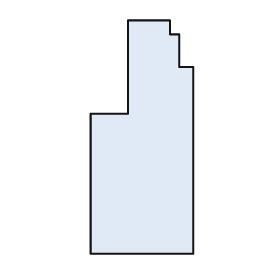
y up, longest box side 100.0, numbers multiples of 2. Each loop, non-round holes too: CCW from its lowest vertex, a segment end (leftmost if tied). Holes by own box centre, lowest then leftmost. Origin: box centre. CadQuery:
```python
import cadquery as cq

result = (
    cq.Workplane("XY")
    .moveTo(-22.0, -50.0)
    .lineTo(22.0, -50.0)
    .lineTo(22.0, 30.0)
    .lineTo(16.0, 30.0)
    .lineTo(16.0, 44.0)
    .lineTo(12.0, 44.0)
    .lineTo(12.0, 50.0)
    .lineTo(-6.0, 50.0)
    .lineTo(-6.0, 10.0)
    .lineTo(-22.0, 10.0)
    .close()
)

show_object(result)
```